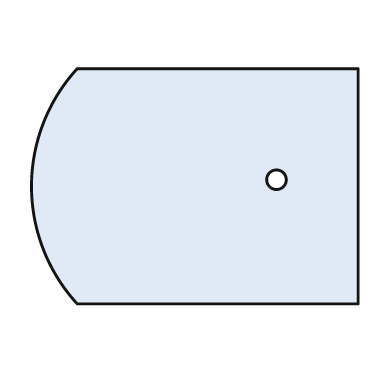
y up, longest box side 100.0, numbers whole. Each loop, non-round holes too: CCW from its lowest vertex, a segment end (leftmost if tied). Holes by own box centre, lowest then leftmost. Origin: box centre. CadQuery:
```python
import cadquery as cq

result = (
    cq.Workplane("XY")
    .moveTo(-36.0, -36.0)
    .lineTo(50.0, -36.0)
    .lineTo(50.0, 36.0)
    .lineTo(-36.0, 36.0)
    .threePointArc((-50.0, 0.0), (-36.0, -36.0))
    .close()
    .moveTo(25.0, 2.0)
    .circle(3.0)
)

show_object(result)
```